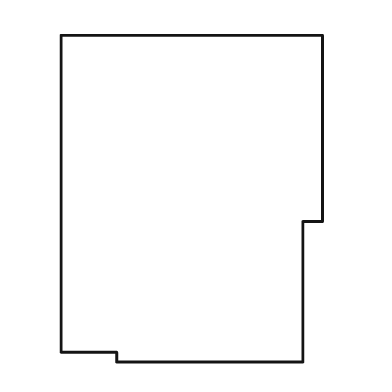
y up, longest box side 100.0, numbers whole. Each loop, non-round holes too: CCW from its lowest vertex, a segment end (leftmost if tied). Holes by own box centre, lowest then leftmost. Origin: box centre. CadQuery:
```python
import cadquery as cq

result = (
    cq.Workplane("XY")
    .moveTo(-23.0, -50.0)
    .lineTo(34.0, -50.0)
    .lineTo(34.0, -7.0)
    .lineTo(40.0, -7.0)
    .lineTo(40.0, 50.0)
    .lineTo(-40.0, 50.0)
    .lineTo(-40.0, -47.0)
    .lineTo(-23.0, -47.0)
    .close()
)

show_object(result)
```